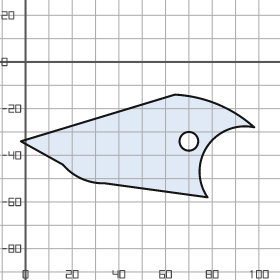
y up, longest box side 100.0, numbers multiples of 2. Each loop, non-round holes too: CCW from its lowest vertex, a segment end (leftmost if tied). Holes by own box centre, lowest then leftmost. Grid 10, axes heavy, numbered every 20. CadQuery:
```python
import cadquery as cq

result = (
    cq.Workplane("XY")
    .moveTo(78.0, -58.0)
    .threePointArc((78.0, -36.0), (98.0, -28.0))
    .threePointArc((82.0, -18.0), (64.0, -14.0))
    .lineTo(-2.0, -34.0)
    .lineTo(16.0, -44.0)
    .threePointArc((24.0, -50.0), (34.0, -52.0))
    .close()
    .moveTo(70.0, -34.0)
    .circle(4.0)
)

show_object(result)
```